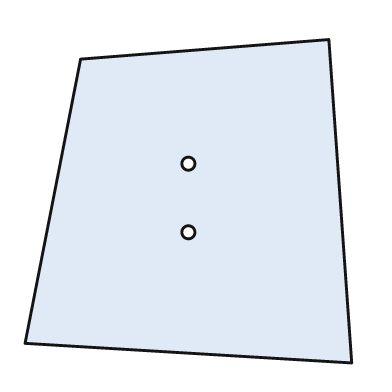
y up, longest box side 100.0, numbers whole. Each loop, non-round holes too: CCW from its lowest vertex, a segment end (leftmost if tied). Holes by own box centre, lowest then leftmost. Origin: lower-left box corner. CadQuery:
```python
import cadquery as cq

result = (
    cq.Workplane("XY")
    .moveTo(100.0, 0.0)
    .lineTo(93.0, 99.0)
    .lineTo(17.0, 93.0)
    .lineTo(0.0, 6.0)
    .close()
    .moveTo(50.0, 40.0)
    .circle(2.0)
    .moveTo(50.0, 61.0)
    .circle(2.0)
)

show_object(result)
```